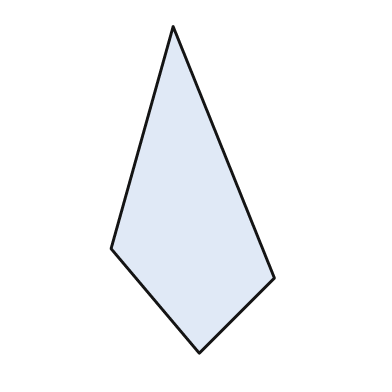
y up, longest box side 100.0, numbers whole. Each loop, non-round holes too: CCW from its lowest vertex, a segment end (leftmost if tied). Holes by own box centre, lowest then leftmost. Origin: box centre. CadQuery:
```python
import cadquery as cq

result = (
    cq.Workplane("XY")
    .moveTo(2.0, -50.0)
    .lineTo(25.0, -27.0)
    .lineTo(-6.0, 50.0)
    .lineTo(-25.0, -18.0)
    .close()
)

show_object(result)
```